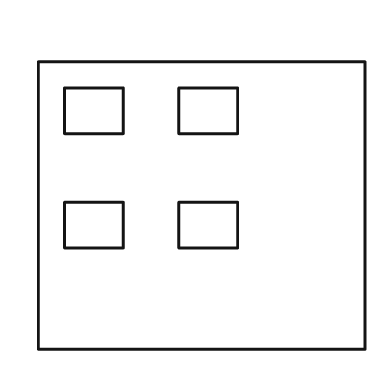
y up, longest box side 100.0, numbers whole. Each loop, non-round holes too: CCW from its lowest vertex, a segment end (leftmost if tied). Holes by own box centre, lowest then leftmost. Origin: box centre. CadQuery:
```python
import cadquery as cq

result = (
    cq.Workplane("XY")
    .moveTo(-50.0, -44.0)
    .lineTo(50.0, -44.0)
    .lineTo(50.0, 44.0)
    .lineTo(-50.0, 44.0)
    .close()
    .moveTo(-42.0, -13.0)
    .lineTo(-24.0, -13.0)
    .lineTo(-24.0, 1.0)
    .lineTo(-42.0, 1.0)
    .close()
    .moveTo(-7.0, -13.0)
    .lineTo(11.0, -13.0)
    .lineTo(11.0, 1.0)
    .lineTo(-7.0, 1.0)
    .close()
    .moveTo(-42.0, 22.0)
    .lineTo(-24.0, 22.0)
    .lineTo(-24.0, 36.0)
    .lineTo(-42.0, 36.0)
    .close()
    .moveTo(-7.0, 22.0)
    .lineTo(11.0, 22.0)
    .lineTo(11.0, 36.0)
    .lineTo(-7.0, 36.0)
    .close()
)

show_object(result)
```